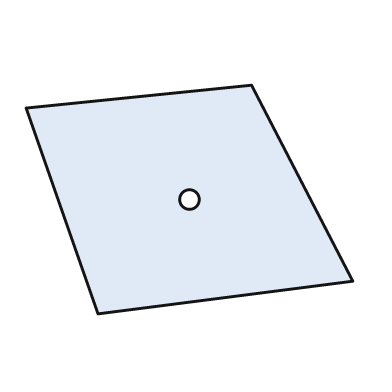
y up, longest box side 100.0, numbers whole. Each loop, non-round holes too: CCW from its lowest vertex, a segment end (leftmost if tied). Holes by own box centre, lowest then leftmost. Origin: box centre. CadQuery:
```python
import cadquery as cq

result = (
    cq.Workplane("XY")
    .moveTo(-28.0, -35.0)
    .lineTo(50.0, -25.0)
    .lineTo(19.0, 35.0)
    .lineTo(-50.0, 28.0)
    .close()
    .moveTo(0.0, 0.0)
    .circle(3.0)
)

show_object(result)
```